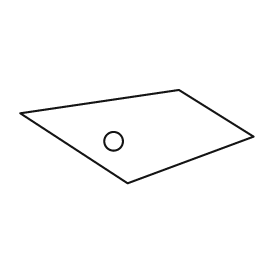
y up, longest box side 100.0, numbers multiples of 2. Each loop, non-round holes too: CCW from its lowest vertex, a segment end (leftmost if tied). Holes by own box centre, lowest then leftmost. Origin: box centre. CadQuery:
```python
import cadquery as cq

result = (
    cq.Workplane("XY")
    .moveTo(-4.0, -20.0)
    .lineTo(50.0, 0.0)
    .lineTo(18.0, 20.0)
    .lineTo(-50.0, 10.0)
    .close()
    .moveTo(-10.0, -2.0)
    .circle(4.0)
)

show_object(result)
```